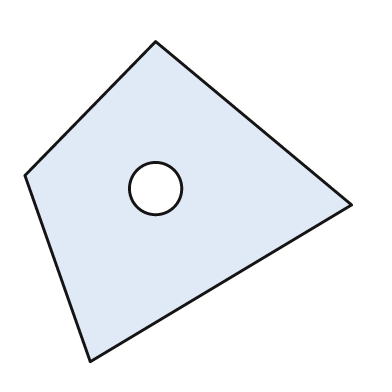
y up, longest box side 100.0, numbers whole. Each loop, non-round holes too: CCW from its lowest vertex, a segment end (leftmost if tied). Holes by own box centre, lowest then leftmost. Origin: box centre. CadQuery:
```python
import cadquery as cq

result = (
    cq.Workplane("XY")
    .moveTo(-30.0, -49.0)
    .lineTo(50.0, -1.0)
    .lineTo(-10.0, 49.0)
    .lineTo(-50.0, 8.0)
    .close()
    .moveTo(-10.0, 4.0)
    .circle(8.0)
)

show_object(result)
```